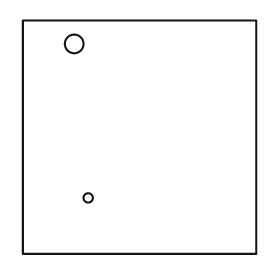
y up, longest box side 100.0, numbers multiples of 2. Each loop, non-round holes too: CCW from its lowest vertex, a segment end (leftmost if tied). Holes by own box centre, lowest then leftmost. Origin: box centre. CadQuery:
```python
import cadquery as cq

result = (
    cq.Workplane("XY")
    .moveTo(-50.0, -50.0)
    .lineTo(50.0, -50.0)
    .lineTo(50.0, 50.0)
    .lineTo(-50.0, 50.0)
    .close()
    .moveTo(-22.0, -26.0)
    .circle(2.0)
    .moveTo(-28.0, 40.0)
    .circle(4.0)
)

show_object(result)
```